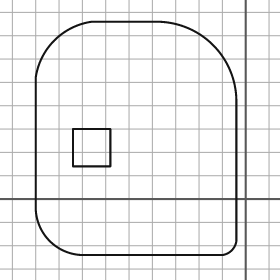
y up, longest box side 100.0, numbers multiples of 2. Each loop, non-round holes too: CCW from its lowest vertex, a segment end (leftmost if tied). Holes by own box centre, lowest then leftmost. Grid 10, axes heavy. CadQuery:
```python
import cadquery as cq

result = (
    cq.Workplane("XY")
    .moveTo(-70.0, -24.0)
    .lineTo(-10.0, -24.0)
    .threePointArc((-6.0, -22.0), (-4.0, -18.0))
    .lineTo(-4.0, 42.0)
    .threePointArc((-14.0, 66.0), (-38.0, 76.0))
    .lineTo(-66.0, 76.0)
    .threePointArc((-82.0, 68.0), (-90.0, 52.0))
    .lineTo(-90.0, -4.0)
    .threePointArc((-84.0, -18.0), (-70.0, -24.0))
    .close()
    .moveTo(-74.0, 14.0)
    .lineTo(-58.0, 14.0)
    .lineTo(-58.0, 30.0)
    .lineTo(-74.0, 30.0)
    .close()
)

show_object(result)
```